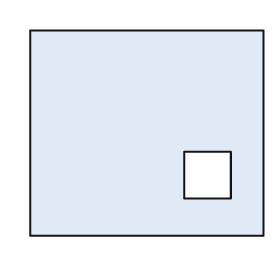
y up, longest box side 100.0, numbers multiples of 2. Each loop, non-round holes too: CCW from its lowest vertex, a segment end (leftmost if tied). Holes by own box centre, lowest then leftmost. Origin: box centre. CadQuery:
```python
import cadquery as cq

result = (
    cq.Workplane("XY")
    .moveTo(-50.0, -44.0)
    .lineTo(50.0, -44.0)
    .lineTo(50.0, 44.0)
    .lineTo(-50.0, 44.0)
    .close()
    .moveTo(16.0, -28.0)
    .lineTo(36.0, -28.0)
    .lineTo(36.0, -8.0)
    .lineTo(16.0, -8.0)
    .close()
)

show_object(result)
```